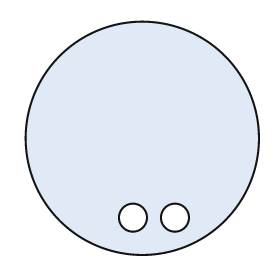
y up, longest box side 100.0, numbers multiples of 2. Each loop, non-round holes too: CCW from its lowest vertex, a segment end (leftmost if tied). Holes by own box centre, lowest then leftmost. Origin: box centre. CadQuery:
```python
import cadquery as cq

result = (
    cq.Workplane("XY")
    .moveTo(0.0, 0.0)
    .circle(50.0)
    .moveTo(-4.0, -34.0)
    .circle(6.0)
    .moveTo(14.0, -34.0)
    .circle(6.0)
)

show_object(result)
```